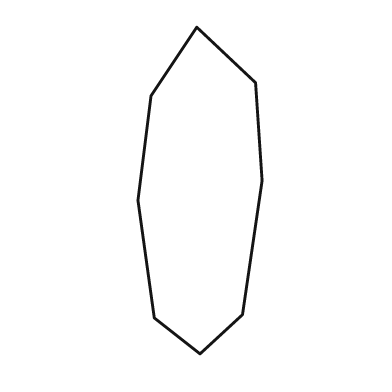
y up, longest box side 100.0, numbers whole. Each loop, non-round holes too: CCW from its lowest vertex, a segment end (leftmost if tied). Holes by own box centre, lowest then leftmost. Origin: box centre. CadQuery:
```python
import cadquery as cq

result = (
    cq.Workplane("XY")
    .moveTo(0.0, -50.0)
    .lineTo(13.0, -38.0)
    .lineTo(19.0, 3.0)
    .lineTo(17.0, 33.0)
    .lineTo(-1.0, 50.0)
    .lineTo(-15.0, 29.0)
    .lineTo(-19.0, -3.0)
    .lineTo(-14.0, -39.0)
    .close()
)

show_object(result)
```